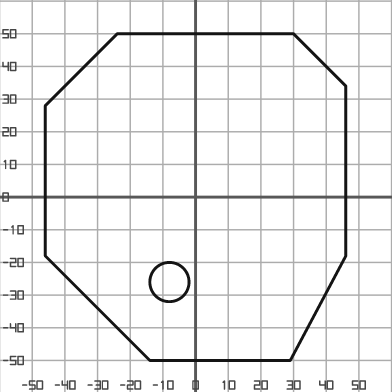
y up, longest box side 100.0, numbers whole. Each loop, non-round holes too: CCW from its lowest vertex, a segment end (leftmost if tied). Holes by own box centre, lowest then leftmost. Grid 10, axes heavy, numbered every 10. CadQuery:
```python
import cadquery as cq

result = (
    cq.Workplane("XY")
    .moveTo(-14.0, -50.0)
    .lineTo(29.0, -50.0)
    .lineTo(46.0, -18.0)
    .lineTo(46.0, 34.0)
    .lineTo(30.0, 50.0)
    .lineTo(-24.0, 50.0)
    .lineTo(-46.0, 28.0)
    .lineTo(-46.0, -18.0)
    .close()
    .moveTo(-8.0, -26.0)
    .circle(6.0)
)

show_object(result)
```